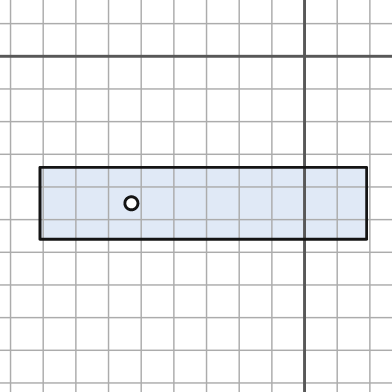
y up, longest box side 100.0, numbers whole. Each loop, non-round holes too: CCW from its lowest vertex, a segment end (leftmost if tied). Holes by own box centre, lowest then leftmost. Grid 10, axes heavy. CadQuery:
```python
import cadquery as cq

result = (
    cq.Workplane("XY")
    .moveTo(-81.0, -56.0)
    .lineTo(19.0, -56.0)
    .lineTo(19.0, -34.0)
    .lineTo(-81.0, -34.0)
    .close()
    .moveTo(-53.0, -45.0)
    .circle(2.0)
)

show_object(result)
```